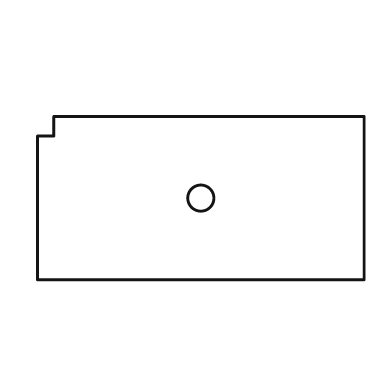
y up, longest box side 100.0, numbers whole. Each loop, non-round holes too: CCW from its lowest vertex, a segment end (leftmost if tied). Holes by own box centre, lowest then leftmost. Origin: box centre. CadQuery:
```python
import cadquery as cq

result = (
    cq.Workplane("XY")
    .moveTo(-50.0, -25.0)
    .lineTo(50.0, -25.0)
    .lineTo(50.0, 25.0)
    .lineTo(-45.0, 25.0)
    .lineTo(-45.0, 19.0)
    .lineTo(-50.0, 19.0)
    .close()
    .moveTo(0.0, 0.0)
    .circle(4.0)
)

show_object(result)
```